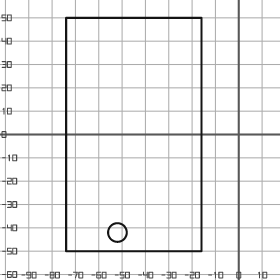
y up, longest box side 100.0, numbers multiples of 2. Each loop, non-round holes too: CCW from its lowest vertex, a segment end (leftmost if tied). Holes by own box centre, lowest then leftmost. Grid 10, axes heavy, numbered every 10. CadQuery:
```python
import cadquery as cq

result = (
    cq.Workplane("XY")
    .moveTo(-74.0, -50.0)
    .lineTo(-16.0, -50.0)
    .lineTo(-16.0, 50.0)
    .lineTo(-74.0, 50.0)
    .close()
    .moveTo(-52.0, -42.0)
    .circle(4.0)
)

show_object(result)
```